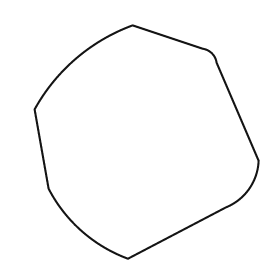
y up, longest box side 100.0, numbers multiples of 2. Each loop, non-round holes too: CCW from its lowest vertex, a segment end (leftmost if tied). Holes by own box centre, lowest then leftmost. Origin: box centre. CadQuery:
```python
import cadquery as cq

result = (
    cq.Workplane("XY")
    .moveTo(-8.0, -50.0)
    .lineTo(34.0, -28.0)
    .threePointArc((44.0, -20.0), (48.0, -8.0))
    .lineTo(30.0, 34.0)
    .threePointArc((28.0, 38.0), (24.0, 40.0))
    .lineTo(-6.0, 50.0)
    .threePointArc((-30.0, 36.0), (-48.0, 14.0))
    .lineTo(-42.0, -20.0)
    .threePointArc((-28.0, -38.0), (-8.0, -50.0))
    .close()
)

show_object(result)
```